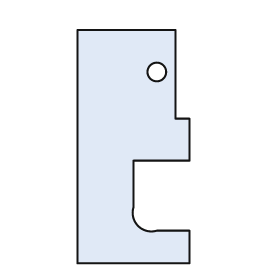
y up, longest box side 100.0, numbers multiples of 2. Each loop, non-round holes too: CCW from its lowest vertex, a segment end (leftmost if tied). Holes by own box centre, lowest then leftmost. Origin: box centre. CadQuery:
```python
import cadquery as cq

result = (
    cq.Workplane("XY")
    .moveTo(-24.0, -50.0)
    .lineTo(24.0, -50.0)
    .lineTo(24.0, -36.0)
    .lineTo(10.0, -36.0)
    .threePointArc((2.0, -34.0), (0.0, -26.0))
    .lineTo(0.0, -6.0)
    .lineTo(24.0, -6.0)
    .lineTo(24.0, 12.0)
    .lineTo(18.0, 12.0)
    .lineTo(18.0, 50.0)
    .lineTo(-24.0, 50.0)
    .close()
    .moveTo(10.0, 32.0)
    .circle(4.0)
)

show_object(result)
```